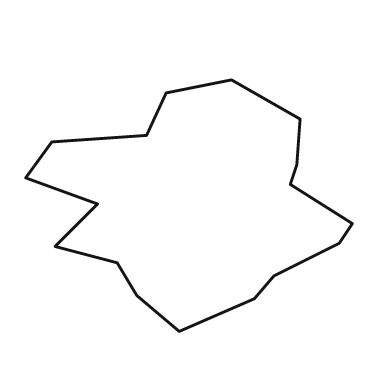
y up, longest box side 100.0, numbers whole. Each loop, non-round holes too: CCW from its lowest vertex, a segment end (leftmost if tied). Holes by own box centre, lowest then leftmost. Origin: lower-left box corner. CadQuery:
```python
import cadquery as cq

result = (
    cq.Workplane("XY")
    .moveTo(47.0, 0.0)
    .lineTo(70.0, 10.0)
    .lineTo(76.0, 17.0)
    .lineTo(96.0, 27.0)
    .lineTo(100.0, 33.0)
    .lineTo(81.0, 45.0)
    .lineTo(83.0, 51.0)
    .lineTo(84.0, 65.0)
    .lineTo(63.0, 77.0)
    .lineTo(43.0, 73.0)
    .lineTo(37.0, 60.0)
    .lineTo(8.0, 58.0)
    .lineTo(0.0, 47.0)
    .lineTo(22.0, 39.0)
    .lineTo(9.0, 26.0)
    .lineTo(28.0, 21.0)
    .lineTo(34.0, 11.0)
    .close()
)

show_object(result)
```